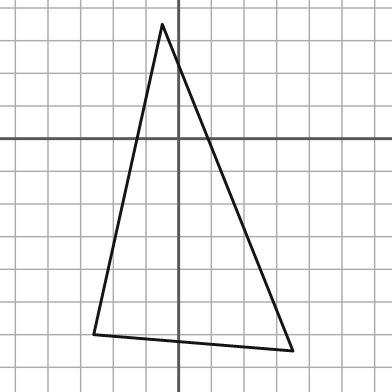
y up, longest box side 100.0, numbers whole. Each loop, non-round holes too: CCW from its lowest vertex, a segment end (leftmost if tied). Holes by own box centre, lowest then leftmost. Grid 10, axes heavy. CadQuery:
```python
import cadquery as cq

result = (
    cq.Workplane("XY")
    .moveTo(35.0, -65.0)
    .lineTo(-5.0, 35.0)
    .lineTo(-26.0, -60.0)
    .close()
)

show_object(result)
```